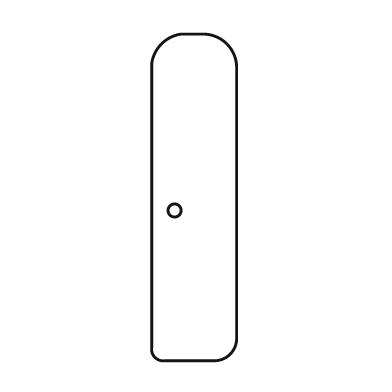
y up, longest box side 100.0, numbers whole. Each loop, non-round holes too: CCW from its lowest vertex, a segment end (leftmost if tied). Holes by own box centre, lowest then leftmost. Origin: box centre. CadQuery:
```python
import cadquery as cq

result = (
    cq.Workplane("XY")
    .moveTo(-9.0, -50.0)
    .lineTo(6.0, -50.0)
    .threePointArc((11.0, -48.0), (13.0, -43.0))
    .lineTo(13.0, 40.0)
    .threePointArc((10.0, 47.0), (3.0, 50.0))
    .lineTo(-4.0, 50.0)
    .threePointArc((-10.0, 47.0), (-13.0, 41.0))
    .lineTo(-13.0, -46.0)
    .threePointArc((-12.0, -49.0), (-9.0, -50.0))
    .close()
    .moveTo(-6.0, -4.0)
    .circle(2.0)
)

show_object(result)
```